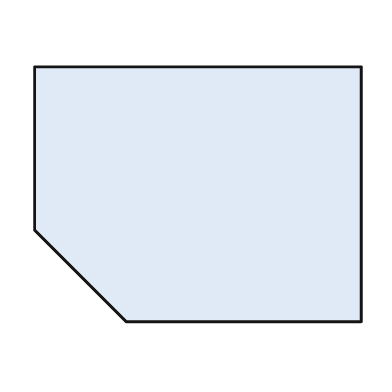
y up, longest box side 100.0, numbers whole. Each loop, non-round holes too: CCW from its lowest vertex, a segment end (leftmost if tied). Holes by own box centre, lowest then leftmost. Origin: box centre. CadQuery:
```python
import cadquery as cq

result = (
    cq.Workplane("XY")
    .moveTo(-22.0, -39.0)
    .lineTo(50.0, -39.0)
    .lineTo(50.0, 39.0)
    .lineTo(-50.0, 39.0)
    .lineTo(-50.0, -11.0)
    .close()
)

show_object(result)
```